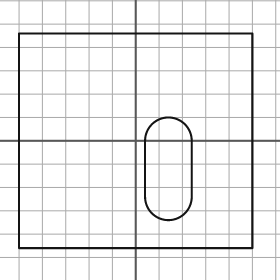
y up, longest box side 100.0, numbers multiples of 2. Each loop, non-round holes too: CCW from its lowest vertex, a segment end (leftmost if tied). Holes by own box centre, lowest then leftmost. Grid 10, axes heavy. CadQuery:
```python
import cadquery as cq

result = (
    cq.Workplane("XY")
    .moveTo(-50.0, -46.0)
    .lineTo(50.0, -46.0)
    .lineTo(50.0, 46.0)
    .lineTo(-50.0, 46.0)
    .close()
    .moveTo(4.0, -24.0)
    .threePointArc((14.0, -34.0), (24.0, -24.0))
    .lineTo(24.0, 0.0)
    .threePointArc((14.0, 10.0), (4.0, 0.0))
    .close()
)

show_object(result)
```